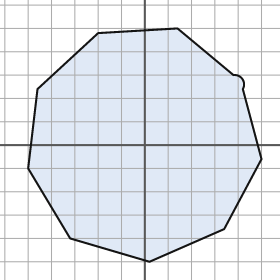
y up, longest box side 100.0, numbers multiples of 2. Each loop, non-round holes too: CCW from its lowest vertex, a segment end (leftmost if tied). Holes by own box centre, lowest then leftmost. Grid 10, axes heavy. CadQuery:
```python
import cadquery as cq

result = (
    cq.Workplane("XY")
    .moveTo(2.0, -50.0)
    .lineTo(34.0, -36.0)
    .lineTo(50.0, -6.0)
    .lineTo(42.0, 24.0)
    .threePointArc((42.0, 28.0), (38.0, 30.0))
    .lineTo(14.0, 50.0)
    .lineTo(-20.0, 48.0)
    .lineTo(-46.0, 24.0)
    .lineTo(-50.0, -10.0)
    .lineTo(-32.0, -40.0)
    .close()
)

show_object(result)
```